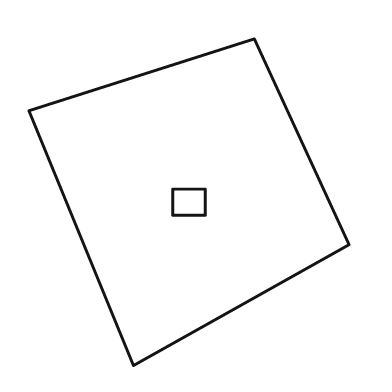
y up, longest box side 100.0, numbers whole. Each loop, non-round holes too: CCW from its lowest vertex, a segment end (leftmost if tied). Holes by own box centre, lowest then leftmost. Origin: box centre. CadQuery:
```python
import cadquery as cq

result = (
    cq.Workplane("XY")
    .moveTo(-17.0, -50.0)
    .lineTo(49.0, -13.0)
    .lineTo(20.0, 50.0)
    .lineTo(-49.0, 28.0)
    .close()
    .moveTo(-5.0, -4.0)
    .lineTo(5.0, -4.0)
    .lineTo(5.0, 4.0)
    .lineTo(-5.0, 4.0)
    .close()
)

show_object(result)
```